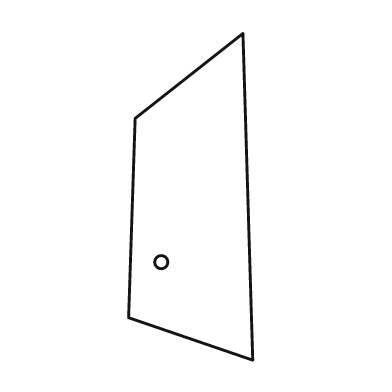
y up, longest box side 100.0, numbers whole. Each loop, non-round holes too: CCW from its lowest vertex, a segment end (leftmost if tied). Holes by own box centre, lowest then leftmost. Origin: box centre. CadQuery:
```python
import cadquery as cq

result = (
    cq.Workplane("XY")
    .moveTo(19.0, -50.0)
    .lineTo(16.0, 50.0)
    .lineTo(-17.0, 24.0)
    .lineTo(-19.0, -37.0)
    .close()
    .moveTo(-9.0, -20.0)
    .circle(2.0)
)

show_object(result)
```